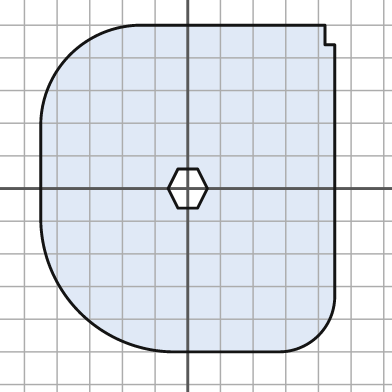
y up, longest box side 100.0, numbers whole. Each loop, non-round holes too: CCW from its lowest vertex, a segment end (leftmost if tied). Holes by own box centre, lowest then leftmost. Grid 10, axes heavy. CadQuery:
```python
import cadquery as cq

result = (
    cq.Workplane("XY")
    .moveTo(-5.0, -50.0)
    .lineTo(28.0, -50.0)
    .threePointArc((40.0, -45.0), (45.0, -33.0))
    .lineTo(45.0, 44.0)
    .lineTo(42.0, 44.0)
    .lineTo(42.0, 50.0)
    .lineTo(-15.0, 50.0)
    .threePointArc((-36.0, 41.0), (-45.0, 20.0))
    .lineTo(-45.0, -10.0)
    .threePointArc((-33.0, -38.0), (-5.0, -50.0))
    .close()
    .moveTo(-3.0, -6.0)
    .lineTo(3.0, -6.0)
    .lineTo(6.0, 0.0)
    .lineTo(3.0, 6.0)
    .lineTo(-3.0, 6.0)
    .lineTo(-6.0, 0.0)
    .close()
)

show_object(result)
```